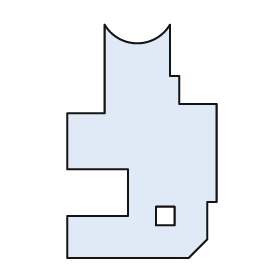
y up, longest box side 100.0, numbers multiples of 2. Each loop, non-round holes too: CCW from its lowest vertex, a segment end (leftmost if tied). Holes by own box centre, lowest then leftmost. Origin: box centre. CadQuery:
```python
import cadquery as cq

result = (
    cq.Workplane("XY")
    .moveTo(-32.0, -50.0)
    .lineTo(20.0, -50.0)
    .lineTo(28.0, -42.0)
    .lineTo(28.0, -26.0)
    .lineTo(32.0, -26.0)
    .lineTo(32.0, 16.0)
    .lineTo(16.0, 16.0)
    .lineTo(16.0, 28.0)
    .lineTo(12.0, 28.0)
    .lineTo(12.0, 50.0)
    .threePointArc((-2.0, 42.0), (-16.0, 50.0))
    .lineTo(-16.0, 12.0)
    .lineTo(-32.0, 12.0)
    .lineTo(-32.0, -12.0)
    .lineTo(-6.0, -12.0)
    .lineTo(-6.0, -32.0)
    .lineTo(-32.0, -32.0)
    .close()
    .moveTo(6.0, -36.0)
    .lineTo(14.0, -36.0)
    .lineTo(14.0, -28.0)
    .lineTo(6.0, -28.0)
    .close()
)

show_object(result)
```